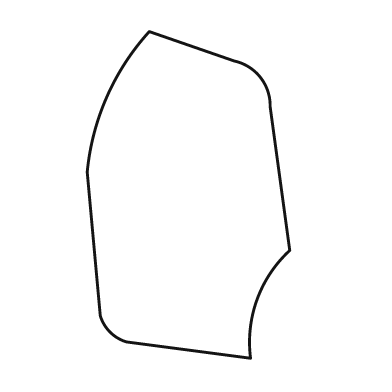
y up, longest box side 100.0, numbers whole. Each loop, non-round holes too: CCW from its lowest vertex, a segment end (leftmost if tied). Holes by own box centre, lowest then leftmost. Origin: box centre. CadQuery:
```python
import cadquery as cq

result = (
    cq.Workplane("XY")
    .moveTo(19.0, -50.0)
    .threePointArc((21.0, -32.0), (31.0, -17.0))
    .lineTo(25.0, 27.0)
    .threePointArc((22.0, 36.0), (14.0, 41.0))
    .lineTo(-12.0, 50.0)
    .threePointArc((-25.0, 30.0), (-31.0, 7.0))
    .lineTo(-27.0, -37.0)
    .threePointArc((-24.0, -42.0), (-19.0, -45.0))
    .close()
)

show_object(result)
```